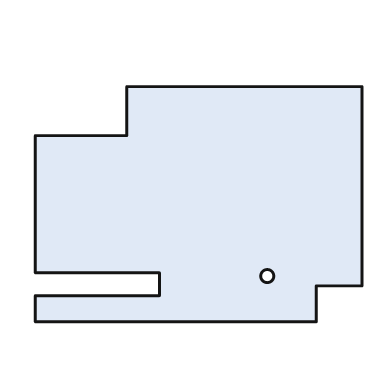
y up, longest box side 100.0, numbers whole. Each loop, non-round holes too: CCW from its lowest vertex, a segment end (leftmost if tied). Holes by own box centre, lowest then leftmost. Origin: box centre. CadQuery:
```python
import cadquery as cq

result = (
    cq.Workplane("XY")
    .moveTo(-50.0, -36.0)
    .lineTo(36.0, -36.0)
    .lineTo(36.0, -25.0)
    .lineTo(50.0, -25.0)
    .lineTo(50.0, 36.0)
    .lineTo(-22.0, 36.0)
    .lineTo(-22.0, 21.0)
    .lineTo(-50.0, 21.0)
    .lineTo(-50.0, -21.0)
    .lineTo(-12.0, -21.0)
    .lineTo(-12.0, -28.0)
    .lineTo(-50.0, -28.0)
    .close()
    .moveTo(21.0, -22.0)
    .circle(2.0)
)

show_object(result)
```